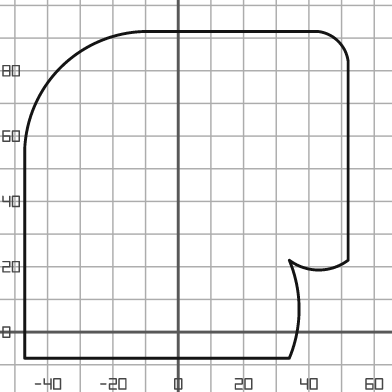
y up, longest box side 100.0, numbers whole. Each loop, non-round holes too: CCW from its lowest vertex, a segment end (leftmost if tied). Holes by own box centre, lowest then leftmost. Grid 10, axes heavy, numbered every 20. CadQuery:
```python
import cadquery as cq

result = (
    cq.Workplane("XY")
    .moveTo(-47.0, -8.0)
    .lineTo(34.0, -8.0)
    .threePointArc((37.0, 7.0), (34.0, 22.0))
    .threePointArc((43.0, 19.0), (52.0, 22.0))
    .lineTo(52.0, 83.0)
    .threePointArc((49.0, 89.0), (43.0, 92.0))
    .lineTo(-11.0, 92.0)
    .threePointArc((-36.0, 81.0), (-47.0, 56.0))
    .close()
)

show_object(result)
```